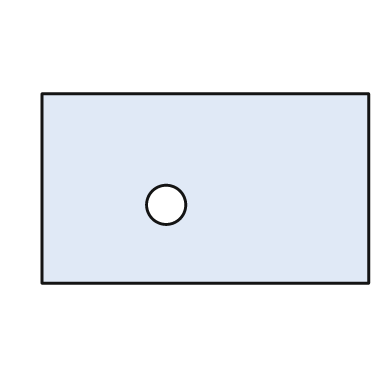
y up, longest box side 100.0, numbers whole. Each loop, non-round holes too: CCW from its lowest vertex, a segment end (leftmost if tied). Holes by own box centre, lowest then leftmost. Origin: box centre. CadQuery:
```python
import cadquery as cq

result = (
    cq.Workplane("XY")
    .moveTo(-50.0, -29.0)
    .lineTo(50.0, -29.0)
    .lineTo(50.0, 29.0)
    .lineTo(-50.0, 29.0)
    .close()
    .moveTo(-12.0, -5.0)
    .circle(6.0)
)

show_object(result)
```